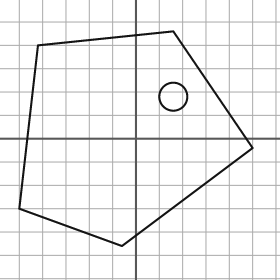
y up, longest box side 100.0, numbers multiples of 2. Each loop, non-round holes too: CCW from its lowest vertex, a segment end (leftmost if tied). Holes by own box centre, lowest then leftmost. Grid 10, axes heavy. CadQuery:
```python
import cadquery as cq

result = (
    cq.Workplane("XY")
    .moveTo(-6.0, -46.0)
    .lineTo(50.0, -4.0)
    .lineTo(16.0, 46.0)
    .lineTo(-42.0, 40.0)
    .lineTo(-50.0, -30.0)
    .close()
    .moveTo(16.0, 18.0)
    .circle(6.0)
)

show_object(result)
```